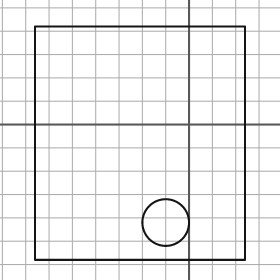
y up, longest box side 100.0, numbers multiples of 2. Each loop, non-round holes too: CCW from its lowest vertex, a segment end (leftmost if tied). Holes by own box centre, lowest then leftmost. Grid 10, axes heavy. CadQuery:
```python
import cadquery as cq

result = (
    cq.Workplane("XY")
    .moveTo(-66.0, -58.0)
    .lineTo(24.0, -58.0)
    .lineTo(24.0, 42.0)
    .lineTo(-66.0, 42.0)
    .close()
    .moveTo(-10.0, -42.0)
    .circle(10.0)
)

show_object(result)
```